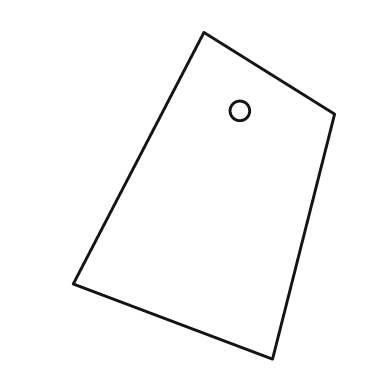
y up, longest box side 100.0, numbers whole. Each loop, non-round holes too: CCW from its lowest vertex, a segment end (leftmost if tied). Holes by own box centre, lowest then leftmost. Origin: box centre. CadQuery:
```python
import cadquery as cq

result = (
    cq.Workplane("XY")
    .moveTo(21.0, -50.0)
    .lineTo(40.0, 25.0)
    .lineTo(0.0, 50.0)
    .lineTo(-40.0, -27.0)
    .close()
    .moveTo(11.0, 26.0)
    .circle(3.0)
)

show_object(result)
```